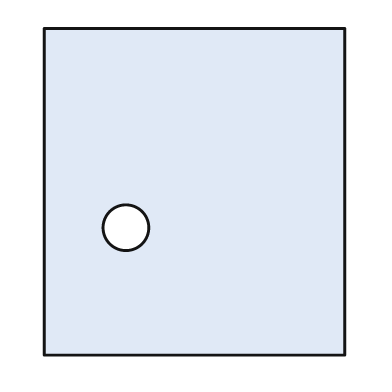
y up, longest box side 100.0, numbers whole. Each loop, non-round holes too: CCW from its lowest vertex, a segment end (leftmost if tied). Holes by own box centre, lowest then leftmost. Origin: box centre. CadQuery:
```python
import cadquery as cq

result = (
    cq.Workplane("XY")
    .moveTo(-46.0, -50.0)
    .lineTo(46.0, -50.0)
    .lineTo(46.0, 50.0)
    .lineTo(-46.0, 50.0)
    .close()
    .moveTo(-21.0, -11.0)
    .circle(7.0)
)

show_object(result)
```